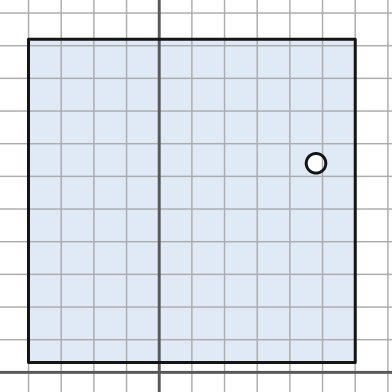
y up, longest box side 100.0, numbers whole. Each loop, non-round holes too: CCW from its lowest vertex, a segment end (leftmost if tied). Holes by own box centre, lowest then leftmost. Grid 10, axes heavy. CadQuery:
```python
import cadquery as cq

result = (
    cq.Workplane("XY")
    .moveTo(-40.0, 3.0)
    .lineTo(60.0, 3.0)
    .lineTo(60.0, 102.0)
    .lineTo(-40.0, 102.0)
    .close()
    .moveTo(48.0, 64.0)
    .circle(3.0)
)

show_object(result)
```